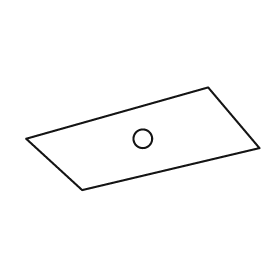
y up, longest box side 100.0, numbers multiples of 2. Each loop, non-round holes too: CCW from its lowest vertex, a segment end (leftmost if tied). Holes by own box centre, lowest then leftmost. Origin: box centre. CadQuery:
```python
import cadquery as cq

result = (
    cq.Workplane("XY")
    .moveTo(-26.0, -22.0)
    .lineTo(50.0, -4.0)
    .lineTo(28.0, 22.0)
    .lineTo(-50.0, 0.0)
    .close()
    .moveTo(0.0, 0.0)
    .circle(4.0)
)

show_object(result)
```